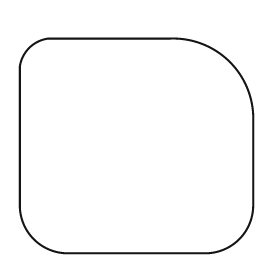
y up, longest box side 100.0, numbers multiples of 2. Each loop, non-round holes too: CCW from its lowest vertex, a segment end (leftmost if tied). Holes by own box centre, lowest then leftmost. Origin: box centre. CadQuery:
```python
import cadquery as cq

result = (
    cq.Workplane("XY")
    .moveTo(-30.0, -46.0)
    .lineTo(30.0, -46.0)
    .threePointArc((44.0, -40.0), (50.0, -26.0))
    .lineTo(50.0, 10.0)
    .threePointArc((40.0, 36.0), (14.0, 46.0))
    .lineTo(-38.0, 46.0)
    .threePointArc((-46.0, 42.0), (-50.0, 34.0))
    .lineTo(-50.0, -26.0)
    .threePointArc((-44.0, -40.0), (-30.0, -46.0))
    .close()
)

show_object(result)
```